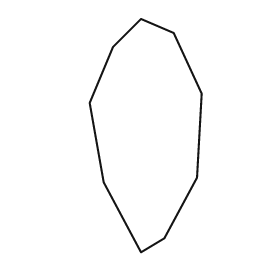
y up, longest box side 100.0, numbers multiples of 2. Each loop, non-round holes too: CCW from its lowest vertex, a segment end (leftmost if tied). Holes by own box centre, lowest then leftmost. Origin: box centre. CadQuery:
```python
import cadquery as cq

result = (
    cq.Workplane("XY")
    .moveTo(-2.0, -50.0)
    .lineTo(8.0, -44.0)
    .lineTo(22.0, -18.0)
    .lineTo(24.0, 18.0)
    .lineTo(12.0, 44.0)
    .lineTo(-2.0, 50.0)
    .lineTo(-14.0, 38.0)
    .lineTo(-24.0, 14.0)
    .lineTo(-18.0, -20.0)
    .close()
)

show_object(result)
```